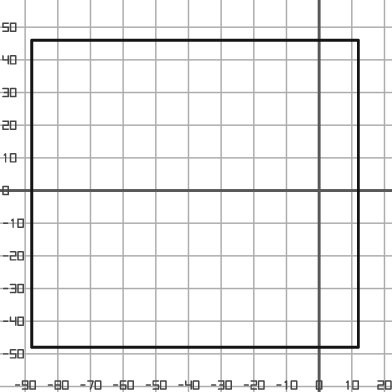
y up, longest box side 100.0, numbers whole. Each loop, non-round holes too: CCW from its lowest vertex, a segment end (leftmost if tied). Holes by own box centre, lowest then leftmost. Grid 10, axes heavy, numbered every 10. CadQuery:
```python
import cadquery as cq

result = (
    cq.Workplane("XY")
    .moveTo(-88.0, -48.0)
    .lineTo(12.0, -48.0)
    .lineTo(12.0, 46.0)
    .lineTo(-88.0, 46.0)
    .close()
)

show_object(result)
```